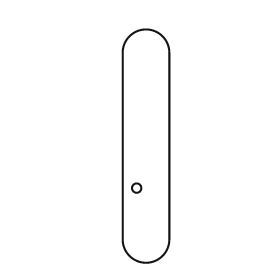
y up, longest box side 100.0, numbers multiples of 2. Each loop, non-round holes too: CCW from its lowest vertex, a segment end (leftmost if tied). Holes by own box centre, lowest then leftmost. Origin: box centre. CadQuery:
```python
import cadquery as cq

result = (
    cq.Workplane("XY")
    .moveTo(-10.0, -40.0)
    .threePointArc((0.0, -50.0), (10.0, -40.0))
    .lineTo(10.0, 40.0)
    .threePointArc((0.0, 50.0), (-10.0, 40.0))
    .close()
    .moveTo(-4.0, -18.0)
    .circle(2.0)
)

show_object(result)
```